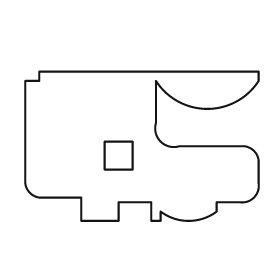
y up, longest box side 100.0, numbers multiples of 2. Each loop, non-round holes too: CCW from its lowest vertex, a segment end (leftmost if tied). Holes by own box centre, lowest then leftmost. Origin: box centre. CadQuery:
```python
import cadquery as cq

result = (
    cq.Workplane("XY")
    .moveTo(-26.0, -32.0)
    .lineTo(-10.0, -32.0)
    .lineTo(-10.0, -24.0)
    .lineTo(4.0, -24.0)
    .lineTo(4.0, -32.0)
    .lineTo(8.0, -32.0)
    .lineTo(8.0, -28.0)
    .threePointArc((20.0, -32.0), (32.0, -28.0))
    .lineTo(32.0, -24.0)
    .lineTo(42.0, -24.0)
    .threePointArc((48.0, -22.0), (50.0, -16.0))
    .lineTo(50.0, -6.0)
    .threePointArc((48.0, -2.0), (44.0, 0.0))
    .lineTo(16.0, 0.0)
    .threePointArc((8.0, 2.0), (6.0, 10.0))
    .lineTo(6.0, 28.0)
    .threePointArc((28.0, 16.0), (50.0, 28.0))
    .lineTo(50.0, 32.0)
    .lineTo(-44.0, 32.0)
    .lineTo(-44.0, 28.0)
    .lineTo(-50.0, 28.0)
    .lineTo(-50.0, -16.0)
    .threePointArc((-48.0, -20.0), (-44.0, -22.0))
    .lineTo(-26.0, -22.0)
    .close()
    .moveTo(-16.0, -10.0)
    .lineTo(-4.0, -10.0)
    .lineTo(-4.0, 2.0)
    .lineTo(-16.0, 2.0)
    .close()
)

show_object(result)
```